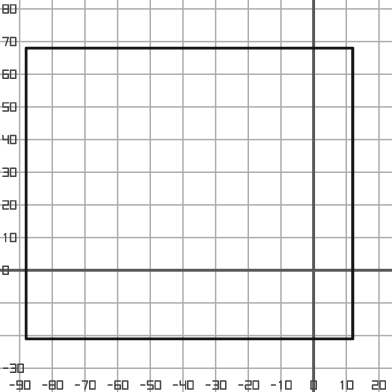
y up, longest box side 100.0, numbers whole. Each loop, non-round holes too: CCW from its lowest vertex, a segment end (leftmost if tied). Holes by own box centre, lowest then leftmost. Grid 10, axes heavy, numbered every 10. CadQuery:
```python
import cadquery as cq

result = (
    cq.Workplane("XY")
    .moveTo(-88.0, -21.0)
    .lineTo(12.0, -21.0)
    .lineTo(12.0, 68.0)
    .lineTo(-88.0, 68.0)
    .close()
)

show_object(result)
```